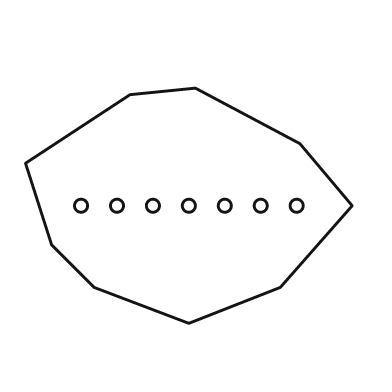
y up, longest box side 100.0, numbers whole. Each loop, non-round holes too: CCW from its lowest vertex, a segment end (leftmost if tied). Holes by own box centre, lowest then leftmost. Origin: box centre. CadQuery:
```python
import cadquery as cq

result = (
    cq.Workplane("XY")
    .moveTo(0.0, -36.0)
    .lineTo(28.0, -25.0)
    .lineTo(50.0, 0.0)
    .lineTo(34.0, 19.0)
    .lineTo(2.0, 36.0)
    .lineTo(-18.0, 34.0)
    .lineTo(-50.0, 13.0)
    .lineTo(-42.0, -12.0)
    .lineTo(-29.0, -25.0)
    .close()
    .moveTo(-33.0, 0.0)
    .circle(2.0)
    .moveTo(-22.0, 0.0)
    .circle(2.0)
    .moveTo(-11.0, 0.0)
    .circle(2.0)
    .moveTo(0.0, 0.0)
    .circle(2.0)
    .moveTo(11.0, 0.0)
    .circle(2.0)
    .moveTo(22.0, 0.0)
    .circle(2.0)
    .moveTo(33.0, 0.0)
    .circle(2.0)
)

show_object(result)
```